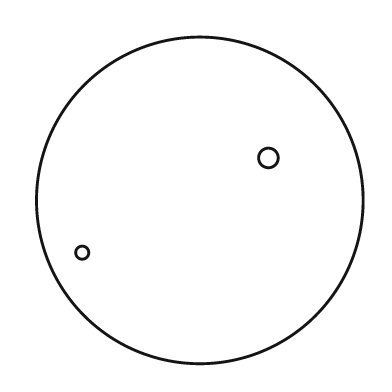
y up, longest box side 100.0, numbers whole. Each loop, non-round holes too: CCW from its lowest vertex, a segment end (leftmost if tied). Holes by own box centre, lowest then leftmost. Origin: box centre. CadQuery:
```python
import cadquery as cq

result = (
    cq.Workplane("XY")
    .moveTo(0.0, 0.0)
    .circle(50.0)
    .moveTo(-36.0, -16.0)
    .circle(2.0)
    .moveTo(21.0, 13.0)
    .circle(3.0)
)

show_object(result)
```